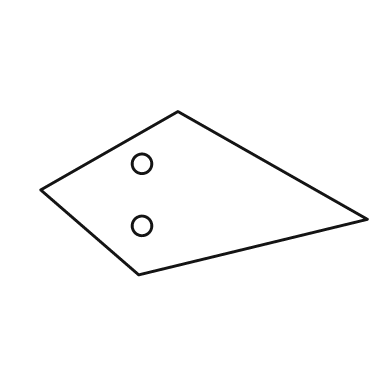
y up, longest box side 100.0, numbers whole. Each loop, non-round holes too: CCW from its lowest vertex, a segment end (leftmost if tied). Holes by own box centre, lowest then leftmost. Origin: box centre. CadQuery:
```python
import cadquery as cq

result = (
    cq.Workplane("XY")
    .moveTo(-20.0, -25.0)
    .lineTo(50.0, -8.0)
    .lineTo(-8.0, 25.0)
    .lineTo(-50.0, 1.0)
    .close()
    .moveTo(-19.0, -10.0)
    .circle(3.0)
    .moveTo(-19.0, 9.0)
    .circle(3.0)
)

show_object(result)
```